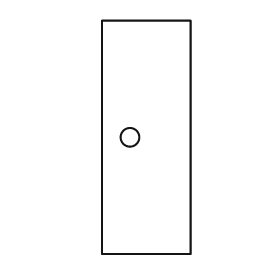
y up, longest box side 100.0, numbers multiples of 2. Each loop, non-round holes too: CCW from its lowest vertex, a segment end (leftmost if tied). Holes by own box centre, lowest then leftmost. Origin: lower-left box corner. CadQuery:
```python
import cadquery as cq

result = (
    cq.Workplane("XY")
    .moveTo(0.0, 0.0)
    .lineTo(38.0, 0.0)
    .lineTo(38.0, 100.0)
    .lineTo(0.0, 100.0)
    .close()
    .moveTo(12.0, 50.0)
    .circle(4.0)
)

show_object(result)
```